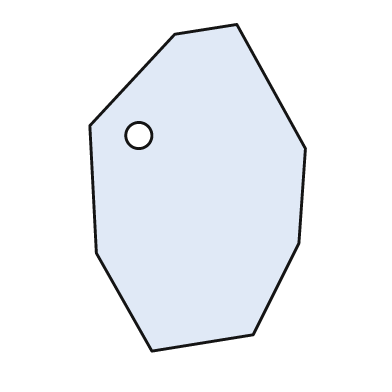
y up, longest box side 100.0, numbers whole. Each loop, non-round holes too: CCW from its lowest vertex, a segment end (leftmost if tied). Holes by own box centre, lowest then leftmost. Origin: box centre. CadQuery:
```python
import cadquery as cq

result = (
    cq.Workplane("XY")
    .moveTo(-14.0, -50.0)
    .lineTo(17.0, -45.0)
    .lineTo(31.0, -17.0)
    .lineTo(33.0, 12.0)
    .lineTo(12.0, 50.0)
    .lineTo(-7.0, 47.0)
    .lineTo(-33.0, 19.0)
    .lineTo(-31.0, -20.0)
    .close()
    .moveTo(-18.0, 16.0)
    .circle(4.0)
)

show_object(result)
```